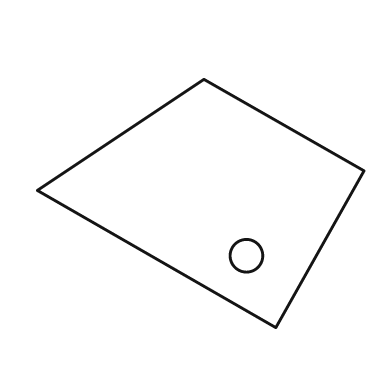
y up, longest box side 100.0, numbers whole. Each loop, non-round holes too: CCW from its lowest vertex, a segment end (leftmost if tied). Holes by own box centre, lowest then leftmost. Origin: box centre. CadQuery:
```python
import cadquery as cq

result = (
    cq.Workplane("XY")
    .moveTo(23.0, -38.0)
    .lineTo(50.0, 10.0)
    .lineTo(1.0, 38.0)
    .lineTo(-50.0, 4.0)
    .close()
    .moveTo(14.0, -16.0)
    .circle(5.0)
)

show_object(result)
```